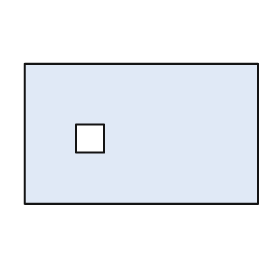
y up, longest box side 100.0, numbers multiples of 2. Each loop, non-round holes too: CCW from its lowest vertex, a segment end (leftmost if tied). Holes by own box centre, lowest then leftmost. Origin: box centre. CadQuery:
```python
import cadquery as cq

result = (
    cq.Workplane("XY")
    .moveTo(-50.0, -30.0)
    .lineTo(50.0, -30.0)
    .lineTo(50.0, 30.0)
    .lineTo(-50.0, 30.0)
    .close()
    .moveTo(-28.0, -8.0)
    .lineTo(-16.0, -8.0)
    .lineTo(-16.0, 4.0)
    .lineTo(-28.0, 4.0)
    .close()
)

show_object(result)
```